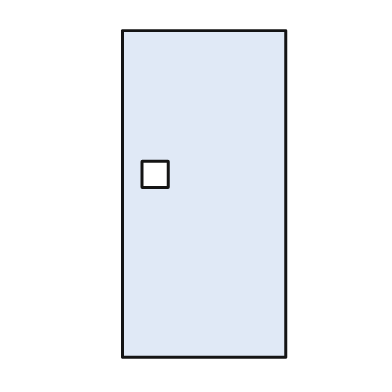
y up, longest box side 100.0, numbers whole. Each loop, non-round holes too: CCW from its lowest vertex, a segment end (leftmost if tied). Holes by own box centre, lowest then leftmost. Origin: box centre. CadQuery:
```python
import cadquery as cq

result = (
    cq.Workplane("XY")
    .moveTo(-25.0, -50.0)
    .lineTo(25.0, -50.0)
    .lineTo(25.0, 50.0)
    .lineTo(-25.0, 50.0)
    .close()
    .moveTo(-19.0, 2.0)
    .lineTo(-11.0, 2.0)
    .lineTo(-11.0, 10.0)
    .lineTo(-19.0, 10.0)
    .close()
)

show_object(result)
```